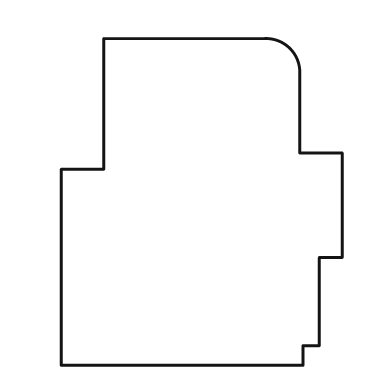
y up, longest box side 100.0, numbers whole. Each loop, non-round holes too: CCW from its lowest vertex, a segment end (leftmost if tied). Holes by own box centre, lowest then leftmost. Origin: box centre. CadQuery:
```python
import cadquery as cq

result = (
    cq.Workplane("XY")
    .moveTo(-43.0, -50.0)
    .lineTo(31.0, -50.0)
    .lineTo(31.0, -44.0)
    .lineTo(36.0, -44.0)
    .lineTo(36.0, -17.0)
    .lineTo(43.0, -17.0)
    .lineTo(43.0, 15.0)
    .lineTo(30.0, 15.0)
    .lineTo(30.0, 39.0)
    .threePointArc((27.0, 47.0), (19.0, 50.0))
    .lineTo(-30.0, 50.0)
    .lineTo(-30.0, 10.0)
    .lineTo(-43.0, 10.0)
    .close()
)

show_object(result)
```